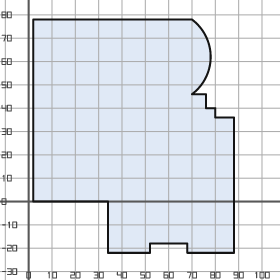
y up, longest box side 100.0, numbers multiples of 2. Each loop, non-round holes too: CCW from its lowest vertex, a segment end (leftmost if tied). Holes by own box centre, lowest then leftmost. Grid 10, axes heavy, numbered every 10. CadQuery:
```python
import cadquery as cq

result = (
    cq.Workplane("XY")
    .moveTo(34.0, -22.0)
    .lineTo(52.0, -22.0)
    .lineTo(52.0, -18.0)
    .lineTo(68.0, -18.0)
    .lineTo(68.0, -22.0)
    .lineTo(88.0, -22.0)
    .lineTo(88.0, 36.0)
    .lineTo(80.0, 36.0)
    .lineTo(80.0, 40.0)
    .lineTo(76.0, 40.0)
    .lineTo(76.0, 46.0)
    .lineTo(70.0, 46.0)
    .threePointArc((78.0, 62.0), (70.0, 78.0))
    .lineTo(2.0, 78.0)
    .lineTo(2.0, 0.0)
    .lineTo(34.0, 0.0)
    .close()
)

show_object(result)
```